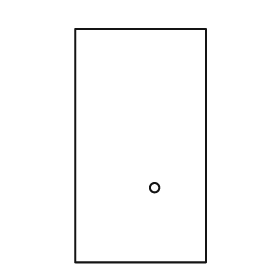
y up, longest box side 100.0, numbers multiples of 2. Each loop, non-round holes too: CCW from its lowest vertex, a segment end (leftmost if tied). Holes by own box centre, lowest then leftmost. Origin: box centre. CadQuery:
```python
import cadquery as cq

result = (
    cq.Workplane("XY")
    .moveTo(-28.0, -50.0)
    .lineTo(28.0, -50.0)
    .lineTo(28.0, 50.0)
    .lineTo(-28.0, 50.0)
    .close()
    .moveTo(6.0, -18.0)
    .circle(2.0)
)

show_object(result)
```